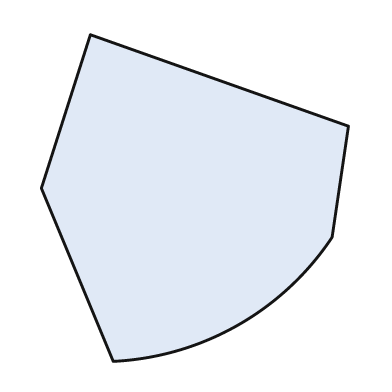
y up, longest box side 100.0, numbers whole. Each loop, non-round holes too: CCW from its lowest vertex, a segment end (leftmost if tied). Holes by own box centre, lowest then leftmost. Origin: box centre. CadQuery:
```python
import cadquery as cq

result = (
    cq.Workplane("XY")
    .moveTo(-25.0, -50.0)
    .threePointArc((13.0, -39.0), (42.0, -12.0))
    .lineTo(47.0, 22.0)
    .lineTo(-32.0, 50.0)
    .lineTo(-47.0, 3.0)
    .close()
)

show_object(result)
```